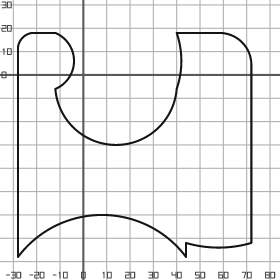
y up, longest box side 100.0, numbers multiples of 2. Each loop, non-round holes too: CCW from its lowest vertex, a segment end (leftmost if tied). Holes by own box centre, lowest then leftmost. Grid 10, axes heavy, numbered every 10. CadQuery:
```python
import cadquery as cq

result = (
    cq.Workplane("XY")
    .moveTo(-28.0, -78.0)
    .threePointArc((8.0, -60.0), (44.0, -78.0))
    .lineTo(44.0, -72.0)
    .threePointArc((58.0, -74.0), (72.0, -72.0))
    .lineTo(72.0, 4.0)
    .threePointArc((68.0, 14.0), (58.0, 18.0))
    .lineTo(40.0, 18.0)
    .threePointArc((42.0, 6.0), (40.0, -6.0))
    .threePointArc((14.0, -30.0), (-12.0, -6.0))
    .threePointArc((-4.0, 6.0), (-12.0, 18.0))
    .lineTo(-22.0, 18.0)
    .threePointArc((-26.0, 16.0), (-28.0, 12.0))
    .close()
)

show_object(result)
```